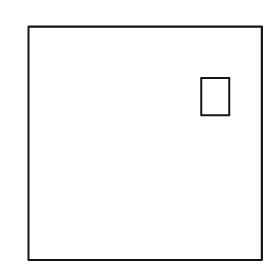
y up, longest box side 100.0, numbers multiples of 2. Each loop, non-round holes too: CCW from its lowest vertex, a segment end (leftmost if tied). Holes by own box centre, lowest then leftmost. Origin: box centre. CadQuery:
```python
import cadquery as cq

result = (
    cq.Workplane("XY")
    .moveTo(-50.0, -50.0)
    .lineTo(50.0, -50.0)
    .lineTo(50.0, 50.0)
    .lineTo(-50.0, 50.0)
    .close()
    .moveTo(24.0, 12.0)
    .lineTo(36.0, 12.0)
    .lineTo(36.0, 28.0)
    .lineTo(24.0, 28.0)
    .close()
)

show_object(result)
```